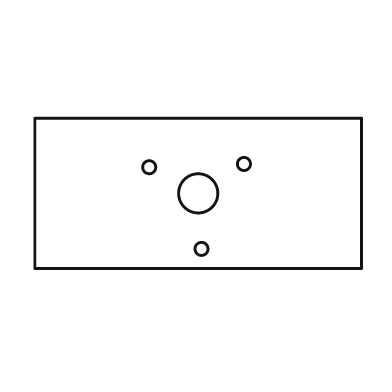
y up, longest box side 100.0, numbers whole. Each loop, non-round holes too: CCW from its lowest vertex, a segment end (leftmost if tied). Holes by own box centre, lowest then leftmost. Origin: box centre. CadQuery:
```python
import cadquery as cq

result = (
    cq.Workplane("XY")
    .moveTo(-50.0, -23.0)
    .lineTo(50.0, -23.0)
    .lineTo(50.0, 23.0)
    .lineTo(-50.0, 23.0)
    .close()
    .moveTo(1.0, -17.0)
    .circle(2.0)
    .moveTo(0.0, 0.0)
    .circle(6.0)
    .moveTo(-15.0, 8.0)
    .circle(2.0)
    .moveTo(14.0, 9.0)
    .circle(2.0)
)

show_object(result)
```